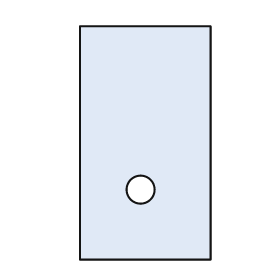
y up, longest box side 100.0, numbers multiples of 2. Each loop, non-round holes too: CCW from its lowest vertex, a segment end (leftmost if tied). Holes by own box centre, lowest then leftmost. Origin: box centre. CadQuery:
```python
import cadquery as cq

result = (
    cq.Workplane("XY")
    .moveTo(-28.0, -50.0)
    .lineTo(28.0, -50.0)
    .lineTo(28.0, 50.0)
    .lineTo(-28.0, 50.0)
    .close()
    .moveTo(-2.0, -20.0)
    .circle(6.0)
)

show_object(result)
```